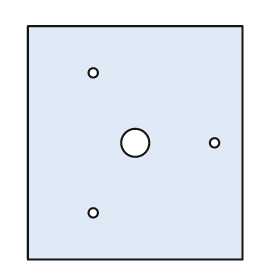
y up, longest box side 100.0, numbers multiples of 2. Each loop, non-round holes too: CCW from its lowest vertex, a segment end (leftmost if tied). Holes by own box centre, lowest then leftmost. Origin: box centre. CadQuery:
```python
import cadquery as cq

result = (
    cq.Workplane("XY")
    .moveTo(-46.0, -50.0)
    .lineTo(46.0, -50.0)
    .lineTo(46.0, 50.0)
    .lineTo(-46.0, 50.0)
    .close()
    .moveTo(-18.0, -30.0)
    .circle(2.0)
    .moveTo(0.0, 0.0)
    .circle(6.0)
    .moveTo(34.0, 0.0)
    .circle(2.0)
    .moveTo(-18.0, 30.0)
    .circle(2.0)
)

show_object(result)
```